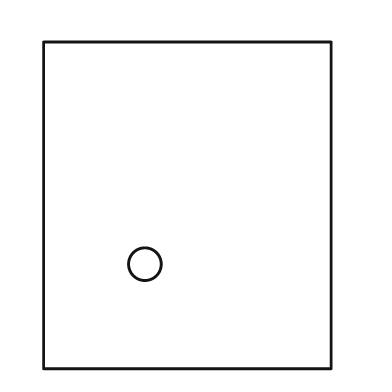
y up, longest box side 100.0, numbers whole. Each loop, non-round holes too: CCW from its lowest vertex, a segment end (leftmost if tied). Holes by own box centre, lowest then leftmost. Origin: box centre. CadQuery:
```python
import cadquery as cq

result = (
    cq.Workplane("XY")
    .moveTo(-44.0, -50.0)
    .lineTo(44.0, -50.0)
    .lineTo(44.0, 50.0)
    .lineTo(-44.0, 50.0)
    .close()
    .moveTo(-13.0, -18.0)
    .circle(5.0)
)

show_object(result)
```